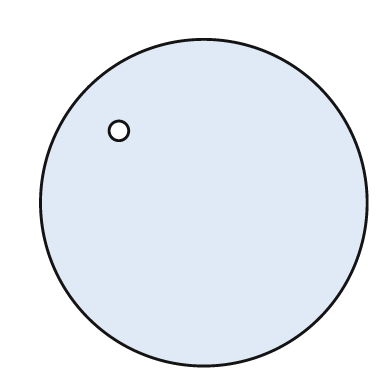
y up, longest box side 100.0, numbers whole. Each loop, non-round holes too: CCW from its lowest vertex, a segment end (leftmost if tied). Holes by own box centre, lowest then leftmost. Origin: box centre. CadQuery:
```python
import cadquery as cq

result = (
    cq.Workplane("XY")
    .moveTo(0.0, 0.0)
    .circle(50.0)
    .moveTo(-26.0, 22.0)
    .circle(3.0)
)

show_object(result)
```